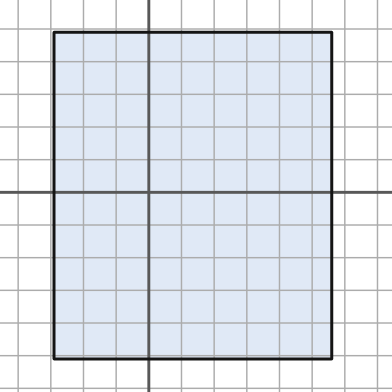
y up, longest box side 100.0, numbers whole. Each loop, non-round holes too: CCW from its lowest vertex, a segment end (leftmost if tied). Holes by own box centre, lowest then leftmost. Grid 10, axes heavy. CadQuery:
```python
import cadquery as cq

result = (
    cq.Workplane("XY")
    .moveTo(-29.0, -51.0)
    .lineTo(56.0, -51.0)
    .lineTo(56.0, 49.0)
    .lineTo(-29.0, 49.0)
    .close()
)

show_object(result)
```